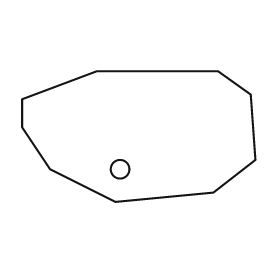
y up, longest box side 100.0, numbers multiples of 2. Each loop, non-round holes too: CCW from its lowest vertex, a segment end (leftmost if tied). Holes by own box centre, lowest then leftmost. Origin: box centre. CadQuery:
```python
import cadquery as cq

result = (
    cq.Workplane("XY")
    .moveTo(-10.0, -28.0)
    .lineTo(32.0, -24.0)
    .lineTo(50.0, -10.0)
    .lineTo(48.0, 18.0)
    .lineTo(34.0, 28.0)
    .lineTo(-18.0, 28.0)
    .lineTo(-50.0, 16.0)
    .lineTo(-50.0, 4.0)
    .lineTo(-38.0, -14.0)
    .close()
    .moveTo(-8.0, -14.0)
    .circle(4.0)
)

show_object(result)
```